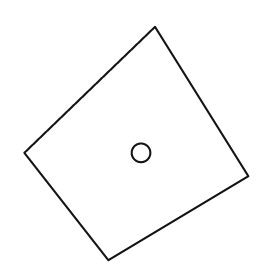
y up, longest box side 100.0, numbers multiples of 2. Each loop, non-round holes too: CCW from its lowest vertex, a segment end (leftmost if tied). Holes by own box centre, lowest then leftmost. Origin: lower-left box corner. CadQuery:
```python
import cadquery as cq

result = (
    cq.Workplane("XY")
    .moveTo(36.0, 0.0)
    .lineTo(96.0, 36.0)
    .lineTo(56.0, 100.0)
    .lineTo(0.0, 46.0)
    .close()
    .moveTo(50.0, 46.0)
    .circle(4.0)
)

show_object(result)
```